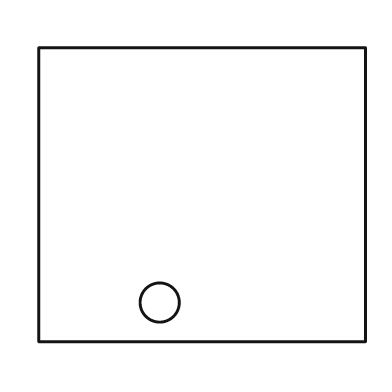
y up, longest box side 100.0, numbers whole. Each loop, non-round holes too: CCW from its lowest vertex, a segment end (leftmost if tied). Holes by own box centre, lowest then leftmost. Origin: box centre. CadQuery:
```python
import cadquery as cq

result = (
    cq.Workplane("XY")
    .moveTo(-50.0, -45.0)
    .lineTo(50.0, -45.0)
    .lineTo(50.0, 45.0)
    .lineTo(-50.0, 45.0)
    .close()
    .moveTo(-13.0, -33.0)
    .circle(6.0)
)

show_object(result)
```